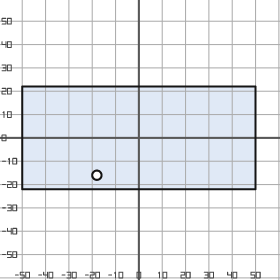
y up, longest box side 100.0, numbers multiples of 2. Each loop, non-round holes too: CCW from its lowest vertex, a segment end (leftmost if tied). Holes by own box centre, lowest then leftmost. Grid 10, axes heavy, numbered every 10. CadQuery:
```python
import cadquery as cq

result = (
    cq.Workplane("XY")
    .moveTo(-50.0, -22.0)
    .lineTo(50.0, -22.0)
    .lineTo(50.0, 22.0)
    .lineTo(-50.0, 22.0)
    .close()
    .moveTo(-18.0, -16.0)
    .circle(2.0)
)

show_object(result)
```